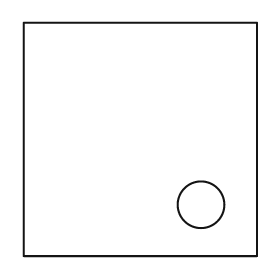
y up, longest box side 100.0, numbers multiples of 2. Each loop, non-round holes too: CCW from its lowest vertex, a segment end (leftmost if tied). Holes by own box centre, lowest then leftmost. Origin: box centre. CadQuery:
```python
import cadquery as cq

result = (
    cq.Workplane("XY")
    .moveTo(-50.0, -50.0)
    .lineTo(50.0, -50.0)
    .lineTo(50.0, 50.0)
    .lineTo(-50.0, 50.0)
    .close()
    .moveTo(26.0, -28.0)
    .circle(10.0)
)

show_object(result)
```